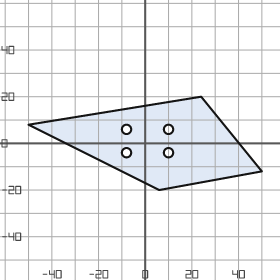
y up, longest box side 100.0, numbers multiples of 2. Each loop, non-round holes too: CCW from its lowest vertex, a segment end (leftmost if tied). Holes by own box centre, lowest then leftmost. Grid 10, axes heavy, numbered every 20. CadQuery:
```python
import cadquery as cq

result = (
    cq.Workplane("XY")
    .moveTo(6.0, -20.0)
    .lineTo(50.0, -12.0)
    .lineTo(24.0, 20.0)
    .lineTo(-50.0, 8.0)
    .close()
    .moveTo(-8.0, -4.0)
    .circle(2.0)
    .moveTo(10.0, -4.0)
    .circle(2.0)
    .moveTo(-8.0, 6.0)
    .circle(2.0)
    .moveTo(10.0, 6.0)
    .circle(2.0)
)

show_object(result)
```